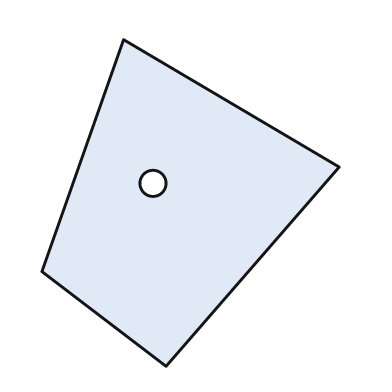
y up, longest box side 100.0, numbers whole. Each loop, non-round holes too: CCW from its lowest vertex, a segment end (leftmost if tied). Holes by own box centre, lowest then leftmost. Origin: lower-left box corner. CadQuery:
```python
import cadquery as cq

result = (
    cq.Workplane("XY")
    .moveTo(38.0, 0.0)
    .lineTo(91.0, 61.0)
    .lineTo(25.0, 100.0)
    .lineTo(0.0, 29.0)
    .close()
    .moveTo(34.0, 56.0)
    .circle(4.0)
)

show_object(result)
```